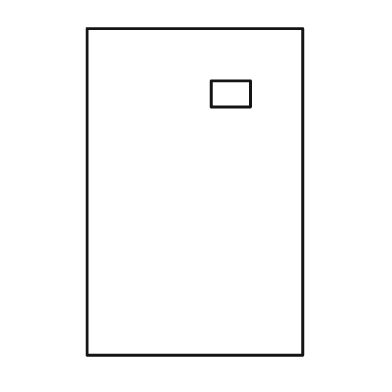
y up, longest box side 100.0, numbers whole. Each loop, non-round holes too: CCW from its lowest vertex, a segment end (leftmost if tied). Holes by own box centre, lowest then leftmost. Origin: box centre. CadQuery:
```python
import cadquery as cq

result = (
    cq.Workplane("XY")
    .moveTo(-33.0, -50.0)
    .lineTo(33.0, -50.0)
    .lineTo(33.0, 50.0)
    .lineTo(-33.0, 50.0)
    .close()
    .moveTo(5.0, 26.0)
    .lineTo(17.0, 26.0)
    .lineTo(17.0, 34.0)
    .lineTo(5.0, 34.0)
    .close()
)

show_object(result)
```